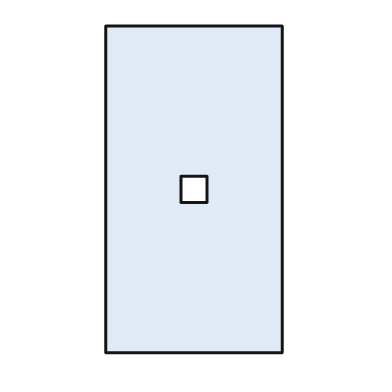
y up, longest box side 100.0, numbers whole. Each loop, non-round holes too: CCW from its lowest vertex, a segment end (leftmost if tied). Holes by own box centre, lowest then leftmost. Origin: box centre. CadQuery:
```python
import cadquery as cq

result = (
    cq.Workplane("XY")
    .moveTo(-27.0, -50.0)
    .lineTo(27.0, -50.0)
    .lineTo(27.0, 50.0)
    .lineTo(-27.0, 50.0)
    .close()
    .moveTo(-4.0, -4.0)
    .lineTo(4.0, -4.0)
    .lineTo(4.0, 4.0)
    .lineTo(-4.0, 4.0)
    .close()
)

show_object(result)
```